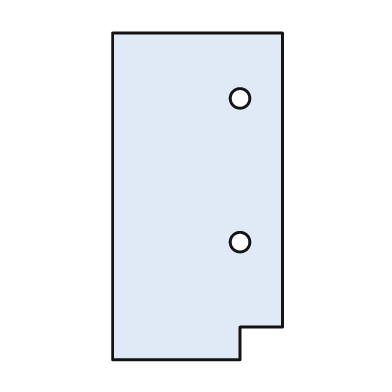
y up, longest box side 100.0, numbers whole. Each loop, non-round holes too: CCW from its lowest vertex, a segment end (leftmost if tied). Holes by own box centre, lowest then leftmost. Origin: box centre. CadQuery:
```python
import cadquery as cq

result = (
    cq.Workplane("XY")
    .moveTo(-26.0, -50.0)
    .lineTo(13.0, -50.0)
    .lineTo(13.0, -40.0)
    .lineTo(26.0, -40.0)
    .lineTo(26.0, 50.0)
    .lineTo(-26.0, 50.0)
    .close()
    .moveTo(13.0, -14.0)
    .circle(3.0)
    .moveTo(13.0, 30.0)
    .circle(3.0)
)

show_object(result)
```